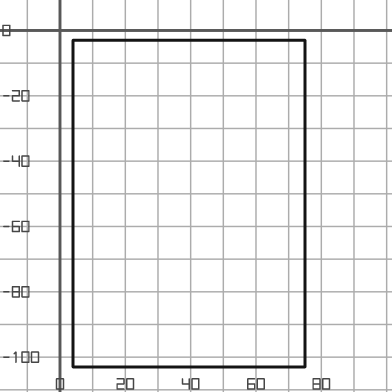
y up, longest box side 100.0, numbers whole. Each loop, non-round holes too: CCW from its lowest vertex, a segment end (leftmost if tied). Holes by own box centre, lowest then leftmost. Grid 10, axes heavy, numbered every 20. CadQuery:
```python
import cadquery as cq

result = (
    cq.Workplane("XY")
    .moveTo(4.0, -103.0)
    .lineTo(75.0, -103.0)
    .lineTo(75.0, -3.0)
    .lineTo(4.0, -3.0)
    .close()
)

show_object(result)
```